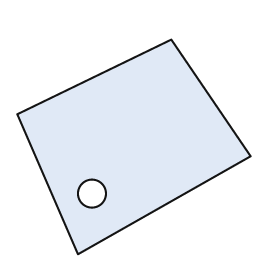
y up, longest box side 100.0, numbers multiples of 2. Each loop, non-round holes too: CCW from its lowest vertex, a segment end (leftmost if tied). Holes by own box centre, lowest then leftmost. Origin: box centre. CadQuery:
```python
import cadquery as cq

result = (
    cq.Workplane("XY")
    .moveTo(-24.0, -46.0)
    .lineTo(50.0, -4.0)
    .lineTo(16.0, 46.0)
    .lineTo(-50.0, 14.0)
    .close()
    .moveTo(-18.0, -20.0)
    .circle(6.0)
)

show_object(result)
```